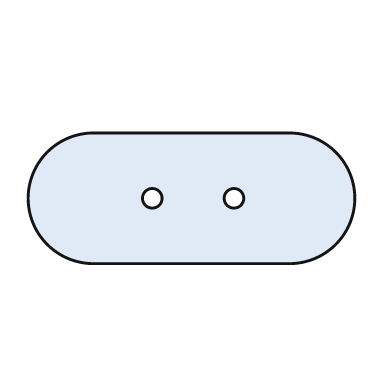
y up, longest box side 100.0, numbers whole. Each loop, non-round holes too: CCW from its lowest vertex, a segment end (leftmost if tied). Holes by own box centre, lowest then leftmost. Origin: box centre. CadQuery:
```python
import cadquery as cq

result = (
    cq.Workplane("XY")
    .moveTo(-30.0, -20.0)
    .lineTo(30.0, -20.0)
    .threePointArc((50.0, 0.0), (30.0, 20.0))
    .lineTo(-30.0, 20.0)
    .threePointArc((-50.0, 0.0), (-30.0, -20.0))
    .close()
    .moveTo(-12.0, 0.0)
    .circle(3.0)
    .moveTo(13.0, 0.0)
    .circle(3.0)
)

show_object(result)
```